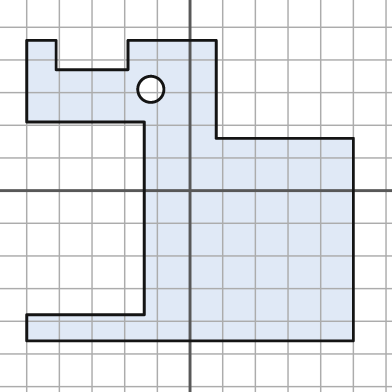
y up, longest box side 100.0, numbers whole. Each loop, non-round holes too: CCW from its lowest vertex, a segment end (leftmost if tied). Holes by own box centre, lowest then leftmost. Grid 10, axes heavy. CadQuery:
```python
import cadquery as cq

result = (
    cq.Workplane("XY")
    .moveTo(-50.0, -46.0)
    .lineTo(50.0, -46.0)
    .lineTo(50.0, 16.0)
    .lineTo(8.0, 16.0)
    .lineTo(8.0, 46.0)
    .lineTo(-19.0, 46.0)
    .lineTo(-19.0, 37.0)
    .lineTo(-41.0, 37.0)
    .lineTo(-41.0, 46.0)
    .lineTo(-50.0, 46.0)
    .lineTo(-50.0, 21.0)
    .lineTo(-14.0, 21.0)
    .lineTo(-14.0, -38.0)
    .lineTo(-50.0, -38.0)
    .close()
    .moveTo(-12.0, 31.0)
    .circle(4.0)
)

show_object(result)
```